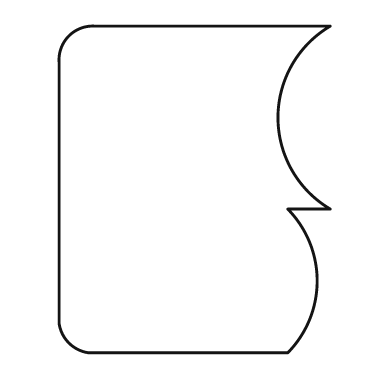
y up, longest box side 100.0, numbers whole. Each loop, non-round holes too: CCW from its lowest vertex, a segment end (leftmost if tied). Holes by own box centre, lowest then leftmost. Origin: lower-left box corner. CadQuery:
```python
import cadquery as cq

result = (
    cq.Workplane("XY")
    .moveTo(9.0, 0.0)
    .lineTo(70.0, 0.0)
    .threePointArc((79.0, 22.0), (70.0, 44.0))
    .lineTo(83.0, 44.0)
    .threePointArc((67.0, 72.0), (83.0, 100.0))
    .lineTo(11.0, 100.0)
    .threePointArc((3.0, 97.0), (0.0, 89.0))
    .lineTo(0.0, 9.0)
    .threePointArc((3.0, 3.0), (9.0, 0.0))
    .close()
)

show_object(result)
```